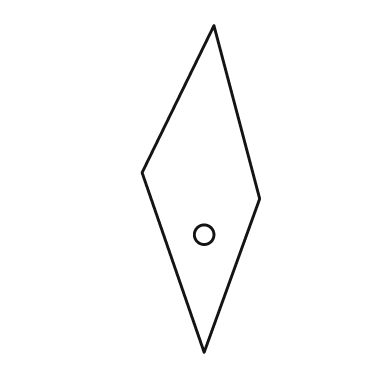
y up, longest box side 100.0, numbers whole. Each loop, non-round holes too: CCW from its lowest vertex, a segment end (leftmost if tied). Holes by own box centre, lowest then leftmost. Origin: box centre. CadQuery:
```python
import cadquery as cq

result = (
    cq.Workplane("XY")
    .moveTo(1.0, -50.0)
    .lineTo(18.0, -3.0)
    .lineTo(4.0, 50.0)
    .lineTo(-18.0, 5.0)
    .close()
    .moveTo(1.0, -14.0)
    .circle(3.0)
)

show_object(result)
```